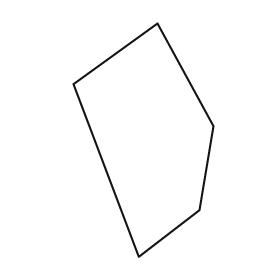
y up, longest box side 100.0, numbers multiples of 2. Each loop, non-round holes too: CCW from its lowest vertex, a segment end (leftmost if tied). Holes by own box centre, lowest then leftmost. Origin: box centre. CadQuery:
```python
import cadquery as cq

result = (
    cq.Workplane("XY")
    .moveTo(-2.0, -50.0)
    .lineTo(24.0, -30.0)
    .lineTo(30.0, 6.0)
    .lineTo(6.0, 50.0)
    .lineTo(-30.0, 24.0)
    .close()
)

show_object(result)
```